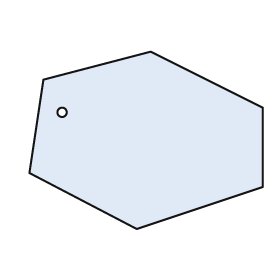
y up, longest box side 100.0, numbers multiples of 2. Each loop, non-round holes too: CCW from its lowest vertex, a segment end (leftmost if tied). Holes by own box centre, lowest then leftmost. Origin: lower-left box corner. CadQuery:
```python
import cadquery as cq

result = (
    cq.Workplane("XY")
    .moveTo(46.0, 0.0)
    .lineTo(100.0, 18.0)
    .lineTo(100.0, 52.0)
    .lineTo(52.0, 76.0)
    .lineTo(6.0, 64.0)
    .lineTo(0.0, 24.0)
    .close()
    .moveTo(14.0, 50.0)
    .circle(2.0)
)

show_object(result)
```